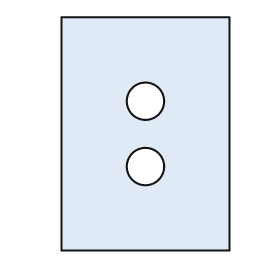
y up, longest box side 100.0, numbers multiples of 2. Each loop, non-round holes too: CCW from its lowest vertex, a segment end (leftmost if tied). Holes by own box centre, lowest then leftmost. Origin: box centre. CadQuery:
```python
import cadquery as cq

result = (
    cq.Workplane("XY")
    .moveTo(-36.0, -50.0)
    .lineTo(36.0, -50.0)
    .lineTo(36.0, 50.0)
    .lineTo(-36.0, 50.0)
    .close()
    .moveTo(0.0, -14.0)
    .circle(8.0)
    .moveTo(0.0, 14.0)
    .circle(8.0)
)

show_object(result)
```